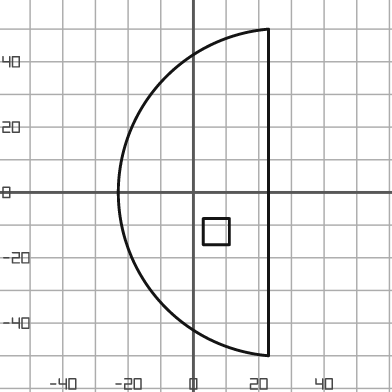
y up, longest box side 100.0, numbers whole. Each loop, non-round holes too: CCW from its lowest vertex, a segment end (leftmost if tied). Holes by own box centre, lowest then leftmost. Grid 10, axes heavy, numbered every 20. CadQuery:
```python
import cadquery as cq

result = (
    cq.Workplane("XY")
    .moveTo(23.0, -50.0)
    .lineTo(23.0, 50.0)
    .threePointArc((-23.0, 0.0), (23.0, -50.0))
    .close()
    .moveTo(3.0, -16.0)
    .lineTo(11.0, -16.0)
    .lineTo(11.0, -8.0)
    .lineTo(3.0, -8.0)
    .close()
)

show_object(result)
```